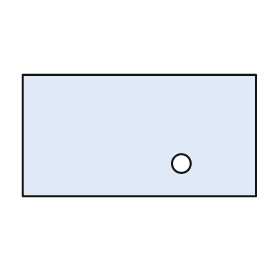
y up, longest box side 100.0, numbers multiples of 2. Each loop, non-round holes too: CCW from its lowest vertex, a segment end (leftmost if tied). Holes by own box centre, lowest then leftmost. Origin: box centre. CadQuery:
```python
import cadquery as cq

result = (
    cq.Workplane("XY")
    .moveTo(-50.0, -26.0)
    .lineTo(50.0, -26.0)
    .lineTo(50.0, 26.0)
    .lineTo(-50.0, 26.0)
    .close()
    .moveTo(18.0, -12.0)
    .circle(4.0)
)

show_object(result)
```